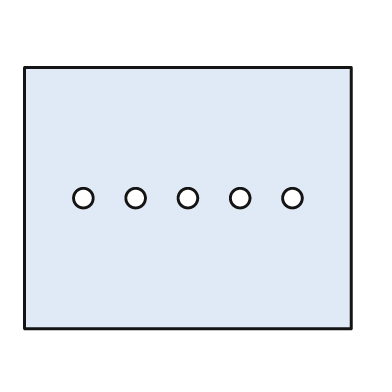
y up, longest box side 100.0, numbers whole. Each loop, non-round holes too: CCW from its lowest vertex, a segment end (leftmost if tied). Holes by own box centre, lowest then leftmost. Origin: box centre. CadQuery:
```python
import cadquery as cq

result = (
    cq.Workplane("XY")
    .moveTo(-50.0, -40.0)
    .lineTo(50.0, -40.0)
    .lineTo(50.0, 40.0)
    .lineTo(-50.0, 40.0)
    .close()
    .moveTo(-32.0, 0.0)
    .circle(3.0)
    .moveTo(-16.0, 0.0)
    .circle(3.0)
    .moveTo(0.0, 0.0)
    .circle(3.0)
    .moveTo(16.0, 0.0)
    .circle(3.0)
    .moveTo(32.0, 0.0)
    .circle(3.0)
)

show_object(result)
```